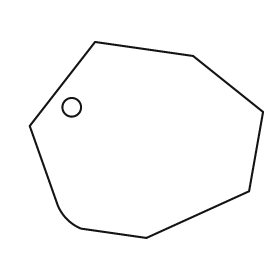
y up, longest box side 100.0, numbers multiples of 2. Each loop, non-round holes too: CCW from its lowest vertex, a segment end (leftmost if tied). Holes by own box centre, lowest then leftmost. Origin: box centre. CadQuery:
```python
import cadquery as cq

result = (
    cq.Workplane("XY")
    .moveTo(0.0, -42.0)
    .lineTo(44.0, -22.0)
    .lineTo(50.0, 12.0)
    .lineTo(20.0, 36.0)
    .lineTo(-22.0, 42.0)
    .lineTo(-50.0, 6.0)
    .lineTo(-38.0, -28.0)
    .threePointArc((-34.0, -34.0), (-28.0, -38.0))
    .close()
    .moveTo(-32.0, 14.0)
    .circle(4.0)
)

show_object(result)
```